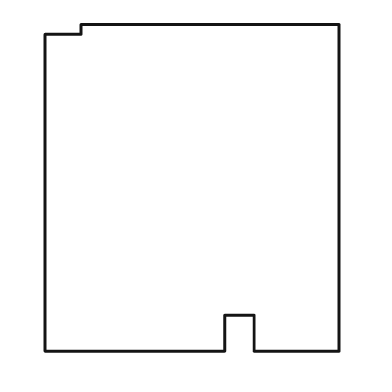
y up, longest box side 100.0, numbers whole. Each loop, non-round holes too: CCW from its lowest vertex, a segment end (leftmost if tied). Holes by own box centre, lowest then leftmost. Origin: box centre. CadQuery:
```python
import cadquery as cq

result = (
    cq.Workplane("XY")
    .moveTo(-45.0, -50.0)
    .lineTo(10.0, -50.0)
    .lineTo(10.0, -39.0)
    .lineTo(19.0, -39.0)
    .lineTo(19.0, -50.0)
    .lineTo(45.0, -50.0)
    .lineTo(45.0, 50.0)
    .lineTo(-34.0, 50.0)
    .lineTo(-34.0, 47.0)
    .lineTo(-45.0, 47.0)
    .close()
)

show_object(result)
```